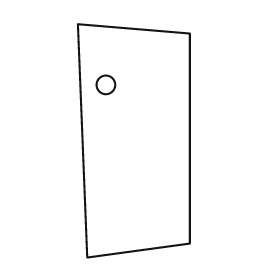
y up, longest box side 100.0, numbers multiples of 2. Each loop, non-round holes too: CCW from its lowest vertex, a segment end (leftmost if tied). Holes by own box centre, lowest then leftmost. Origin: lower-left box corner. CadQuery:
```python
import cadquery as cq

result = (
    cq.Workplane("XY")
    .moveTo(4.0, 0.0)
    .lineTo(48.0, 6.0)
    .lineTo(48.0, 96.0)
    .lineTo(0.0, 100.0)
    .close()
    .moveTo(12.0, 74.0)
    .circle(4.0)
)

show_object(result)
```